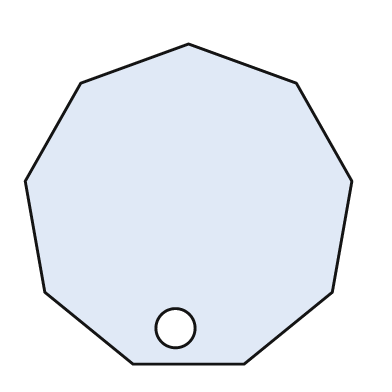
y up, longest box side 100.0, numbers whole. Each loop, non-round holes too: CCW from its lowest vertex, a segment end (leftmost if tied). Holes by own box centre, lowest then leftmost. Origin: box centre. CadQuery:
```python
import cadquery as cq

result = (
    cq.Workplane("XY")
    .moveTo(-17.0, -49.0)
    .lineTo(17.0, -49.0)
    .lineTo(44.0, -27.0)
    .lineTo(50.0, 7.0)
    .lineTo(33.0, 37.0)
    .lineTo(0.0, 49.0)
    .lineTo(-33.0, 37.0)
    .lineTo(-50.0, 7.0)
    .lineTo(-44.0, -27.0)
    .close()
    .moveTo(-4.0, -38.0)
    .circle(6.0)
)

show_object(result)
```